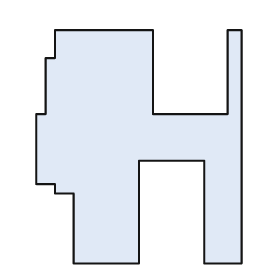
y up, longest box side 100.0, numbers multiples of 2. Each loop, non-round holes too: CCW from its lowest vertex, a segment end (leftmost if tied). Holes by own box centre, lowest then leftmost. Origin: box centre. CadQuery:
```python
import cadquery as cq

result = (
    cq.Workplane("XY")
    .moveTo(-28.0, -50.0)
    .lineTo(0.0, -50.0)
    .lineTo(0.0, -6.0)
    .lineTo(28.0, -6.0)
    .lineTo(28.0, -50.0)
    .lineTo(44.0, -50.0)
    .lineTo(44.0, 50.0)
    .lineTo(38.0, 50.0)
    .lineTo(38.0, 14.0)
    .lineTo(6.0, 14.0)
    .lineTo(6.0, 50.0)
    .lineTo(-36.0, 50.0)
    .lineTo(-36.0, 38.0)
    .lineTo(-40.0, 38.0)
    .lineTo(-40.0, 14.0)
    .lineTo(-44.0, 14.0)
    .lineTo(-44.0, -16.0)
    .lineTo(-36.0, -16.0)
    .lineTo(-36.0, -20.0)
    .lineTo(-28.0, -20.0)
    .close()
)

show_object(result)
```